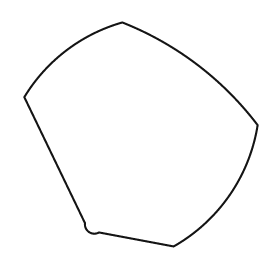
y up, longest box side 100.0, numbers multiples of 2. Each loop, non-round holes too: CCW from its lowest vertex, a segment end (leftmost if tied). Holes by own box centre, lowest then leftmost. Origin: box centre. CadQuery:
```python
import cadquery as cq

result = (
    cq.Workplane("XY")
    .moveTo(14.0, -48.0)
    .threePointArc((38.0, -26.0), (50.0, 4.0))
    .threePointArc((24.0, 30.0), (-8.0, 48.0))
    .threePointArc((-32.0, 36.0), (-50.0, 16.0))
    .lineTo(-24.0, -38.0)
    .threePointArc((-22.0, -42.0), (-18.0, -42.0))
    .close()
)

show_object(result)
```